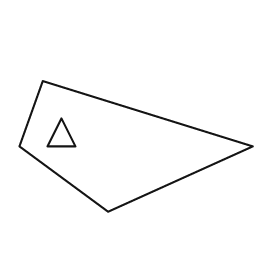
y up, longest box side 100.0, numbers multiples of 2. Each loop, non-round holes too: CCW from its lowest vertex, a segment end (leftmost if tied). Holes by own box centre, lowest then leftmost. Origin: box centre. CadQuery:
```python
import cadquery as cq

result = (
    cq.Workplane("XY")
    .moveTo(-12.0, -28.0)
    .lineTo(50.0, 0.0)
    .lineTo(-40.0, 28.0)
    .lineTo(-50.0, 0.0)
    .close()
    .moveTo(-38.0, 0.0)
    .lineTo(-26.0, 0.0)
    .lineTo(-32.0, 12.0)
    .close()
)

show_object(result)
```